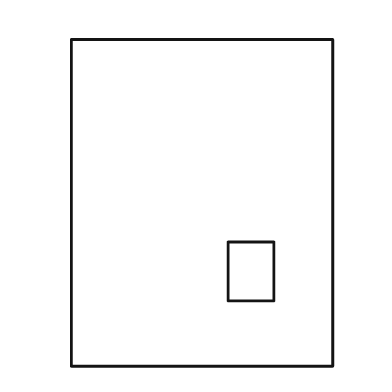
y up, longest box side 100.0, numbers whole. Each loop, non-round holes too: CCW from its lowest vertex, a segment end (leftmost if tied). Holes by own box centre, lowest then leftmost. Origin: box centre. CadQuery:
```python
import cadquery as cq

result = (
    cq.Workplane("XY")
    .moveTo(-40.0, -50.0)
    .lineTo(40.0, -50.0)
    .lineTo(40.0, 50.0)
    .lineTo(-40.0, 50.0)
    .close()
    .moveTo(8.0, -30.0)
    .lineTo(22.0, -30.0)
    .lineTo(22.0, -12.0)
    .lineTo(8.0, -12.0)
    .close()
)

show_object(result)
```